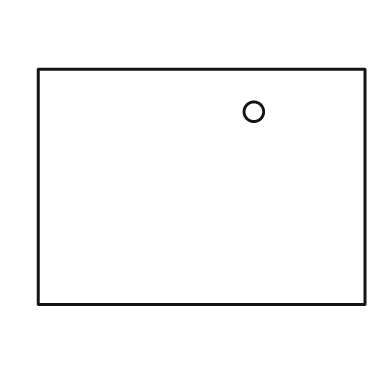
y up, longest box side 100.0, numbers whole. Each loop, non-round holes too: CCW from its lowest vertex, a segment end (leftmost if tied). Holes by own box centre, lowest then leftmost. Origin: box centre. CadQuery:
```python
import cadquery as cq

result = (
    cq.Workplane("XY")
    .moveTo(-50.0, -36.0)
    .lineTo(50.0, -36.0)
    .lineTo(50.0, 36.0)
    .lineTo(-50.0, 36.0)
    .close()
    .moveTo(16.0, 23.0)
    .circle(3.0)
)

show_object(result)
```